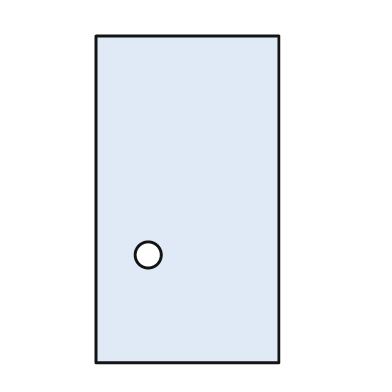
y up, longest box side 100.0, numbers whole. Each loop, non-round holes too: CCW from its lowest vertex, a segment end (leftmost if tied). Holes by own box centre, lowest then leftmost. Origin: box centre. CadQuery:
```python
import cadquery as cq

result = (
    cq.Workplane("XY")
    .moveTo(-28.0, -50.0)
    .lineTo(28.0, -50.0)
    .lineTo(28.0, 50.0)
    .lineTo(-28.0, 50.0)
    .close()
    .moveTo(-12.0, -17.0)
    .circle(4.0)
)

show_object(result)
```